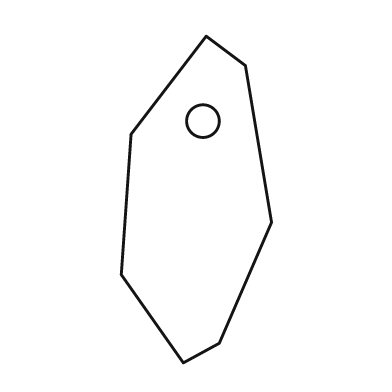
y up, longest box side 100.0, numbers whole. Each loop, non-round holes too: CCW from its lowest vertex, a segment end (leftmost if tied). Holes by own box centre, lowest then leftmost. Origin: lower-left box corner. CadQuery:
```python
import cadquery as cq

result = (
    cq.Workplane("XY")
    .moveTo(19.0, 0.0)
    .lineTo(30.0, 6.0)
    .lineTo(46.0, 43.0)
    .lineTo(38.0, 91.0)
    .lineTo(26.0, 100.0)
    .lineTo(3.0, 70.0)
    .lineTo(0.0, 27.0)
    .close()
    .moveTo(25.0, 74.0)
    .circle(5.0)
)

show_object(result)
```